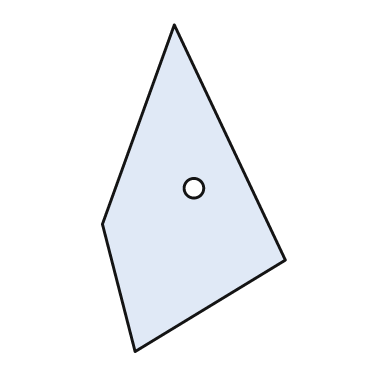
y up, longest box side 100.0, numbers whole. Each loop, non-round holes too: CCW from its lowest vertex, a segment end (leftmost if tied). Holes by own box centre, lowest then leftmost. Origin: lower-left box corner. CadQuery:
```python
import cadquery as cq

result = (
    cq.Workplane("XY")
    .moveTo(10.0, 0.0)
    .lineTo(56.0, 28.0)
    .lineTo(22.0, 100.0)
    .lineTo(0.0, 39.0)
    .close()
    .moveTo(28.0, 50.0)
    .circle(3.0)
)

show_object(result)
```